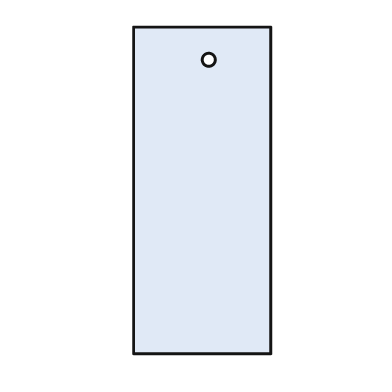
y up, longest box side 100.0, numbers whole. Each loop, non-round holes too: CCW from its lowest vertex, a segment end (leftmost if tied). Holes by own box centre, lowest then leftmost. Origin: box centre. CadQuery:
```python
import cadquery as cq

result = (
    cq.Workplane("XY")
    .moveTo(-21.0, -50.0)
    .lineTo(21.0, -50.0)
    .lineTo(21.0, 50.0)
    .lineTo(-21.0, 50.0)
    .close()
    .moveTo(2.0, 40.0)
    .circle(2.0)
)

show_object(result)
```